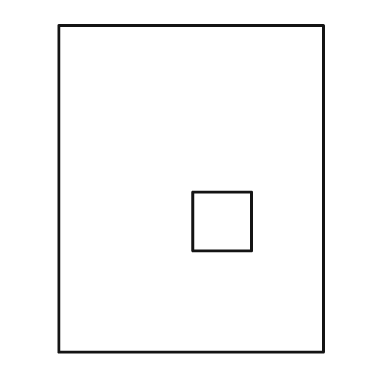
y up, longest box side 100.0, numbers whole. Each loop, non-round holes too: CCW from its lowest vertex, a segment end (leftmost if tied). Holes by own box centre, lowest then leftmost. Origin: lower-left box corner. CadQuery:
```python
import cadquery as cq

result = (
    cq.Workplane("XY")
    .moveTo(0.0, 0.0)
    .lineTo(81.0, 0.0)
    .lineTo(81.0, 100.0)
    .lineTo(0.0, 100.0)
    .close()
    .moveTo(41.0, 31.0)
    .lineTo(59.0, 31.0)
    .lineTo(59.0, 49.0)
    .lineTo(41.0, 49.0)
    .close()
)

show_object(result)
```